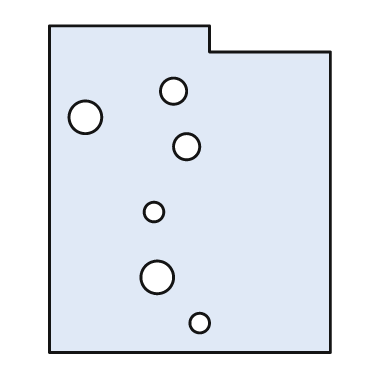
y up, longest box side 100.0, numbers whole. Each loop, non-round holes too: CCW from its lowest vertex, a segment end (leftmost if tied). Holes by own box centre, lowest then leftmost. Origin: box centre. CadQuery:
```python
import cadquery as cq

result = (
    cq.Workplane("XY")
    .moveTo(-43.0, -50.0)
    .lineTo(43.0, -50.0)
    .lineTo(43.0, 42.0)
    .lineTo(6.0, 42.0)
    .lineTo(6.0, 50.0)
    .lineTo(-43.0, 50.0)
    .close()
    .moveTo(3.0, -41.0)
    .circle(3.0)
    .moveTo(-10.0, -27.0)
    .circle(5.0)
    .moveTo(-11.0, -7.0)
    .circle(3.0)
    .moveTo(-1.0, 13.0)
    .circle(4.0)
    .moveTo(-32.0, 22.0)
    .circle(5.0)
    .moveTo(-5.0, 30.0)
    .circle(4.0)
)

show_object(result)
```